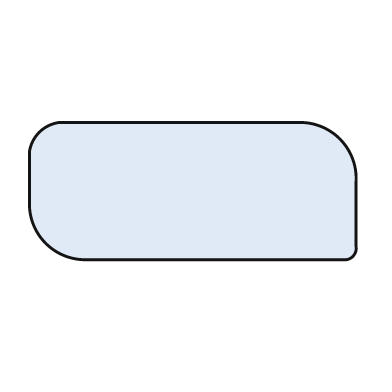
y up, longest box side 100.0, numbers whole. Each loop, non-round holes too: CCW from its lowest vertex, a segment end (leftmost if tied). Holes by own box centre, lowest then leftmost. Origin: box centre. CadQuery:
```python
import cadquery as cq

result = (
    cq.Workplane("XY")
    .moveTo(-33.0, -21.0)
    .lineTo(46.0, -21.0)
    .threePointArc((49.0, -20.0), (50.0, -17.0))
    .lineTo(50.0, 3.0)
    .threePointArc((45.0, 16.0), (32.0, 21.0))
    .lineTo(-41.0, 21.0)
    .threePointArc((-47.0, 18.0), (-50.0, 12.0))
    .lineTo(-50.0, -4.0)
    .threePointArc((-45.0, -16.0), (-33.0, -21.0))
    .close()
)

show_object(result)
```